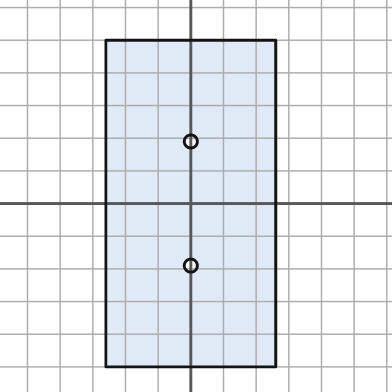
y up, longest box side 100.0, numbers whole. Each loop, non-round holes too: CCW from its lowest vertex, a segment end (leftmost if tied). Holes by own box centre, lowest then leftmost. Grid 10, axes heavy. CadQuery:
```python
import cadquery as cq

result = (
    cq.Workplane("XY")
    .moveTo(-26.0, -50.0)
    .lineTo(26.0, -50.0)
    .lineTo(26.0, 50.0)
    .lineTo(-26.0, 50.0)
    .close()
    .moveTo(0.0, -19.0)
    .circle(2.0)
    .moveTo(0.0, 19.0)
    .circle(2.0)
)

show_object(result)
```